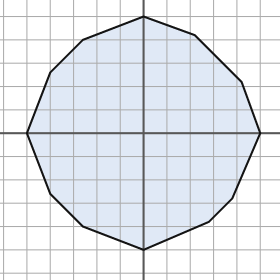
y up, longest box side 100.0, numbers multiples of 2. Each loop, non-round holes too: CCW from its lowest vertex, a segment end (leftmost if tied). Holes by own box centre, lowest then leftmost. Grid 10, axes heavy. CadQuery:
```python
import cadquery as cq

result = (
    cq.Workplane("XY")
    .moveTo(0.0, -50.0)
    .lineTo(28.0, -38.0)
    .lineTo(38.0, -28.0)
    .lineTo(50.0, 0.0)
    .lineTo(42.0, 22.0)
    .lineTo(22.0, 42.0)
    .lineTo(0.0, 50.0)
    .lineTo(-26.0, 40.0)
    .lineTo(-40.0, 26.0)
    .lineTo(-50.0, 0.0)
    .lineTo(-40.0, -26.0)
    .lineTo(-26.0, -40.0)
    .close()
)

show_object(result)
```